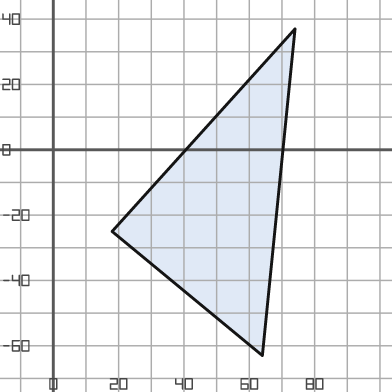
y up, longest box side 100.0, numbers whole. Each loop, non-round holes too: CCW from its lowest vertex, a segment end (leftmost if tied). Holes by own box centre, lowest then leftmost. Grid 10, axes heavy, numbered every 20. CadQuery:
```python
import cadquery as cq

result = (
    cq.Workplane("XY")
    .moveTo(64.0, -63.0)
    .lineTo(74.0, 37.0)
    .lineTo(18.0, -25.0)
    .close()
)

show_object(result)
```